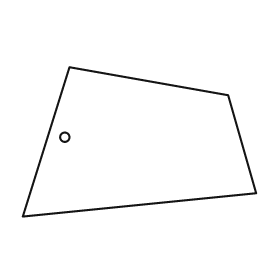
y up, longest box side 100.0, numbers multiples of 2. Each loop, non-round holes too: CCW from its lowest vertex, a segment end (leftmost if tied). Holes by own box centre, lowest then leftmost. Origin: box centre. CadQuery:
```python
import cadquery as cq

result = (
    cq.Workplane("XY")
    .moveTo(-50.0, -32.0)
    .lineTo(50.0, -22.0)
    .lineTo(38.0, 20.0)
    .lineTo(-30.0, 32.0)
    .close()
    .moveTo(-32.0, 2.0)
    .circle(2.0)
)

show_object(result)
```